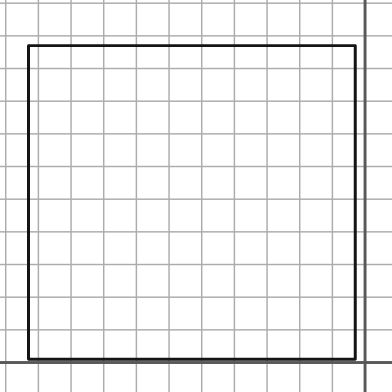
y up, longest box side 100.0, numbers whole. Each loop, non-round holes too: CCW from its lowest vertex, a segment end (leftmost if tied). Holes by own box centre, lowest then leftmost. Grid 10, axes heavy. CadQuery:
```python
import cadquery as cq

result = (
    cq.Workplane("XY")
    .moveTo(-103.0, 1.0)
    .lineTo(-3.0, 1.0)
    .lineTo(-3.0, 97.0)
    .lineTo(-103.0, 97.0)
    .close()
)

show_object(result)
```